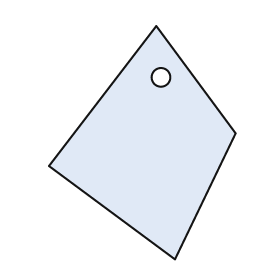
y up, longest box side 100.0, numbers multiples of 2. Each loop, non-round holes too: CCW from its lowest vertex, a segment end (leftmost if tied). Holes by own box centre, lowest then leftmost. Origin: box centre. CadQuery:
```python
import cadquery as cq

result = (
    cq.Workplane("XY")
    .moveTo(14.0, -50.0)
    .lineTo(40.0, 4.0)
    .lineTo(6.0, 50.0)
    .lineTo(-40.0, -10.0)
    .close()
    .moveTo(8.0, 28.0)
    .circle(4.0)
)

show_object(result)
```